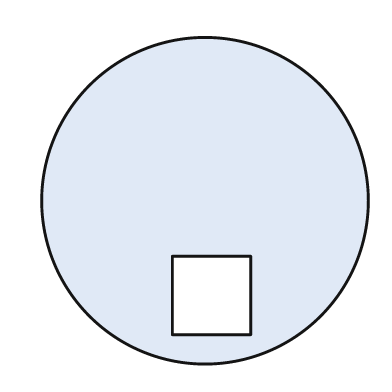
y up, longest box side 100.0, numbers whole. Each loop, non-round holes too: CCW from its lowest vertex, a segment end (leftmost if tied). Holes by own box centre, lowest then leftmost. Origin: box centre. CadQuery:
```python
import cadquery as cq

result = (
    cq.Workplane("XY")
    .moveTo(0.0, 0.0)
    .circle(50.0)
    .moveTo(-10.0, -41.0)
    .lineTo(14.0, -41.0)
    .lineTo(14.0, -17.0)
    .lineTo(-10.0, -17.0)
    .close()
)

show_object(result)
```